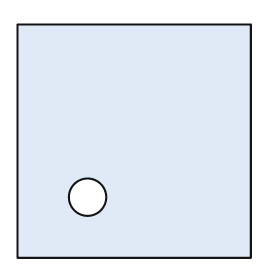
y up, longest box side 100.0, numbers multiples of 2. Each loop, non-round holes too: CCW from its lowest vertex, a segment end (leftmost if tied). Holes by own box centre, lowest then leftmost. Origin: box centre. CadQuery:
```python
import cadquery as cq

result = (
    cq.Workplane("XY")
    .moveTo(-50.0, -50.0)
    .lineTo(50.0, -50.0)
    .lineTo(50.0, 50.0)
    .lineTo(-50.0, 50.0)
    .close()
    .moveTo(-20.0, -24.0)
    .circle(8.0)
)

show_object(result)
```